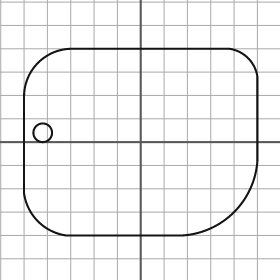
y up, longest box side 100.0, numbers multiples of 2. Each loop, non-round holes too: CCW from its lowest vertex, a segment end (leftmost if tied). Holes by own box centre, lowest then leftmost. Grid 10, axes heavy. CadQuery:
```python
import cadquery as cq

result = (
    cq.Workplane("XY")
    .moveTo(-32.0, -40.0)
    .lineTo(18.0, -40.0)
    .threePointArc((40.0, -30.0), (50.0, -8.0))
    .lineTo(50.0, 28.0)
    .threePointArc((46.0, 36.0), (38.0, 40.0))
    .lineTo(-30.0, 40.0)
    .threePointArc((-44.0, 34.0), (-50.0, 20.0))
    .lineTo(-50.0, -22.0)
    .threePointArc((-44.0, -34.0), (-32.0, -40.0))
    .close()
    .moveTo(-42.0, 4.0)
    .circle(4.0)
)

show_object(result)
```